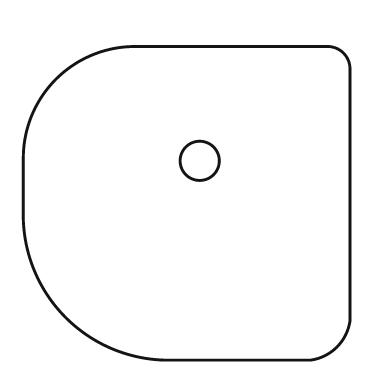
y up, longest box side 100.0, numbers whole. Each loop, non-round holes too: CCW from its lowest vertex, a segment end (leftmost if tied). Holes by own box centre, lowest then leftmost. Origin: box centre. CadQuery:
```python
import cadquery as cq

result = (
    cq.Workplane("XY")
    .moveTo(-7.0, -48.0)
    .lineTo(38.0, -48.0)
    .threePointArc((46.0, -44.0), (50.0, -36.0))
    .lineTo(50.0, 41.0)
    .threePointArc((48.0, 46.0), (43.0, 48.0))
    .lineTo(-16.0, 48.0)
    .threePointArc((-40.0, 38.0), (-50.0, 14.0))
    .lineTo(-50.0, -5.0)
    .threePointArc((-37.0, -35.0), (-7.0, -48.0))
    .close()
    .moveTo(4.0, 13.0)
    .circle(6.0)
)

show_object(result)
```